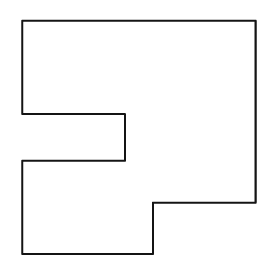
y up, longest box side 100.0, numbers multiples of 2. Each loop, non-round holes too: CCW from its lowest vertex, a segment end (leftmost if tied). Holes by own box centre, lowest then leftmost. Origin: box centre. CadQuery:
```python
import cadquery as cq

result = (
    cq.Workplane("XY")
    .moveTo(-50.0, -50.0)
    .lineTo(6.0, -50.0)
    .lineTo(6.0, -28.0)
    .lineTo(50.0, -28.0)
    .lineTo(50.0, 50.0)
    .lineTo(-50.0, 50.0)
    .lineTo(-50.0, 10.0)
    .lineTo(-6.0, 10.0)
    .lineTo(-6.0, -10.0)
    .lineTo(-50.0, -10.0)
    .close()
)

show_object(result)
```